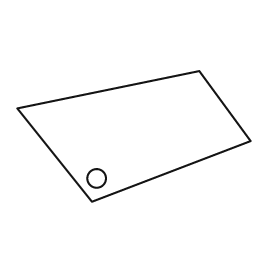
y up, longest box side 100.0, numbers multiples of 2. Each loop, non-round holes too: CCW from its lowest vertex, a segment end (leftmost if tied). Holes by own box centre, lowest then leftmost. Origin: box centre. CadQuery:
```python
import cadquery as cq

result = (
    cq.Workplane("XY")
    .moveTo(-18.0, -28.0)
    .lineTo(50.0, -2.0)
    .lineTo(28.0, 28.0)
    .lineTo(-50.0, 12.0)
    .close()
    .moveTo(-16.0, -18.0)
    .circle(4.0)
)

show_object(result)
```